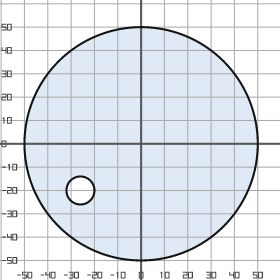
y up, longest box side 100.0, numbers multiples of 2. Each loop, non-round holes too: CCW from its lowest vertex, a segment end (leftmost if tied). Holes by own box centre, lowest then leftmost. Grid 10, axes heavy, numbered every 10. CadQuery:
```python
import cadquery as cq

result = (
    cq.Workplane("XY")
    .moveTo(0.0, 0.0)
    .circle(50.0)
    .moveTo(-26.0, -20.0)
    .circle(6.0)
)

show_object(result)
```